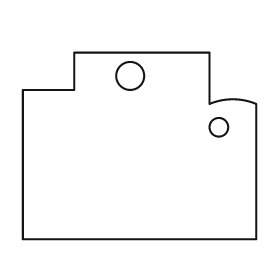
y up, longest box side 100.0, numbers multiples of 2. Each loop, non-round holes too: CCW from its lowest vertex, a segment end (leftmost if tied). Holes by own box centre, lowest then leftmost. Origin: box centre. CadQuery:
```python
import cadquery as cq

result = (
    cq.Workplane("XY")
    .moveTo(-50.0, -40.0)
    .lineTo(50.0, -40.0)
    .lineTo(50.0, 18.0)
    .threePointArc((40.0, 20.0), (30.0, 18.0))
    .lineTo(30.0, 40.0)
    .lineTo(-28.0, 40.0)
    .lineTo(-28.0, 24.0)
    .lineTo(-50.0, 24.0)
    .close()
    .moveTo(34.0, 8.0)
    .circle(4.0)
    .moveTo(-4.0, 30.0)
    .circle(6.0)
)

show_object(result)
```